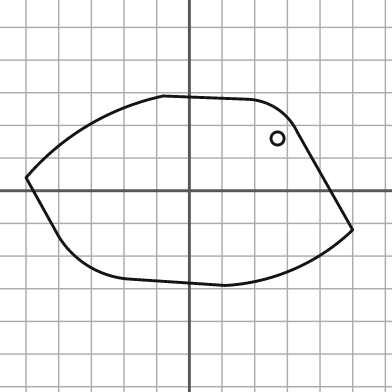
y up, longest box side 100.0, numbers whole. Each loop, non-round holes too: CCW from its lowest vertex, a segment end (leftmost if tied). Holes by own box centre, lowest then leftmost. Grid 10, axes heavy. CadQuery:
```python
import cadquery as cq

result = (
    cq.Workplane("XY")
    .moveTo(11.0, -29.0)
    .threePointArc((32.0, -24.0), (50.0, -12.0))
    .lineTo(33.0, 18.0)
    .threePointArc((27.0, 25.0), (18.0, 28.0))
    .lineTo(-8.0, 29.0)
    .threePointArc((-31.0, 20.0), (-50.0, 4.0))
    .lineTo(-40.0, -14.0)
    .threePointArc((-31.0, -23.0), (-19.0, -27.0))
    .close()
    .moveTo(27.0, 16.0)
    .circle(2.0)
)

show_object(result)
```